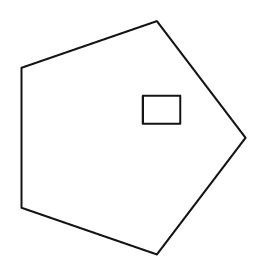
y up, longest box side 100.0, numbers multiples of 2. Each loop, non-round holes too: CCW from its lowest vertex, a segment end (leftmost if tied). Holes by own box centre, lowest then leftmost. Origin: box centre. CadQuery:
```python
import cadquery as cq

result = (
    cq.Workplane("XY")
    .moveTo(10.0, -50.0)
    .lineTo(48.0, 0.0)
    .lineTo(10.0, 50.0)
    .lineTo(-48.0, 30.0)
    .lineTo(-48.0, -30.0)
    .close()
    .moveTo(4.0, 6.0)
    .lineTo(20.0, 6.0)
    .lineTo(20.0, 18.0)
    .lineTo(4.0, 18.0)
    .close()
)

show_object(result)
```